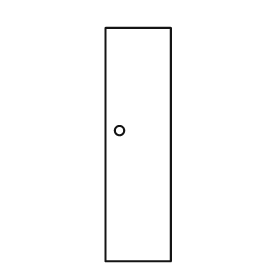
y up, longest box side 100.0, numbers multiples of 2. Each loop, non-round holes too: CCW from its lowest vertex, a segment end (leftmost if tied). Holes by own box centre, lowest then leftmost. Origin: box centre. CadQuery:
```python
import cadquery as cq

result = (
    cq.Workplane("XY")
    .moveTo(-14.0, -50.0)
    .lineTo(14.0, -50.0)
    .lineTo(14.0, 50.0)
    .lineTo(-14.0, 50.0)
    .close()
    .moveTo(-8.0, 6.0)
    .circle(2.0)
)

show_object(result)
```